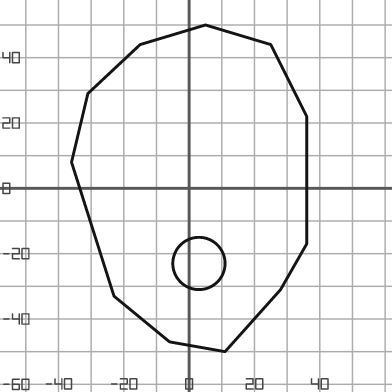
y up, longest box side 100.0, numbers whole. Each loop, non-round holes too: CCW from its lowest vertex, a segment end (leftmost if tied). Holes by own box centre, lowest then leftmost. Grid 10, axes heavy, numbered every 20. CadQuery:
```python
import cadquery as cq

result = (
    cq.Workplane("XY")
    .moveTo(11.0, -50.0)
    .lineTo(28.0, -31.0)
    .lineTo(36.0, -17.0)
    .lineTo(36.0, 22.0)
    .lineTo(25.0, 44.0)
    .lineTo(5.0, 50.0)
    .lineTo(-15.0, 44.0)
    .lineTo(-31.0, 29.0)
    .lineTo(-36.0, 8.0)
    .lineTo(-23.0, -33.0)
    .lineTo(-6.0, -47.0)
    .close()
    .moveTo(3.0, -23.0)
    .circle(8.0)
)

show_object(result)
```